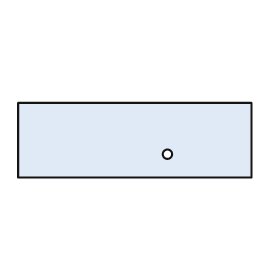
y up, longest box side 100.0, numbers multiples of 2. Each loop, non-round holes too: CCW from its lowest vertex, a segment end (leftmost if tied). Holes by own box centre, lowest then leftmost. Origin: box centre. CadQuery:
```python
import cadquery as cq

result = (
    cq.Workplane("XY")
    .moveTo(-50.0, -16.0)
    .lineTo(50.0, -16.0)
    .lineTo(50.0, 16.0)
    .lineTo(-50.0, 16.0)
    .close()
    .moveTo(14.0, -6.0)
    .circle(2.0)
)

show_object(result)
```